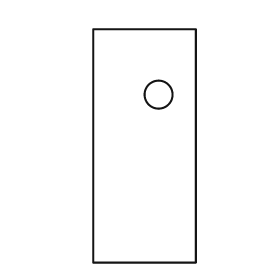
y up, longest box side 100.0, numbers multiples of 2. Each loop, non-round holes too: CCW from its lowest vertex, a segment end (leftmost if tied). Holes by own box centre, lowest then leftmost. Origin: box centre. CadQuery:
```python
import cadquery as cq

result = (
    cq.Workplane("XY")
    .moveTo(-22.0, -50.0)
    .lineTo(22.0, -50.0)
    .lineTo(22.0, 50.0)
    .lineTo(-22.0, 50.0)
    .close()
    .moveTo(6.0, 22.0)
    .circle(6.0)
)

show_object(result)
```